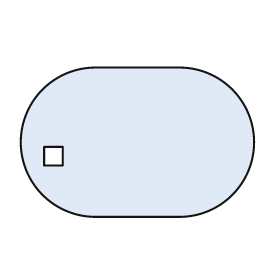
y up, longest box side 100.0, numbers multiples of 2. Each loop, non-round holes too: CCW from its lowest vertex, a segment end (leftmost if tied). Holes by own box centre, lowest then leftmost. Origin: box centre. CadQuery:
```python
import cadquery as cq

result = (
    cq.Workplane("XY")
    .moveTo(-18.0, -32.0)
    .lineTo(18.0, -32.0)
    .threePointArc((50.0, 0.0), (18.0, 32.0))
    .lineTo(-18.0, 32.0)
    .threePointArc((-50.0, 0.0), (-18.0, -32.0))
    .close()
    .moveTo(-40.0, -10.0)
    .lineTo(-32.0, -10.0)
    .lineTo(-32.0, -2.0)
    .lineTo(-40.0, -2.0)
    .close()
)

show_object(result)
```